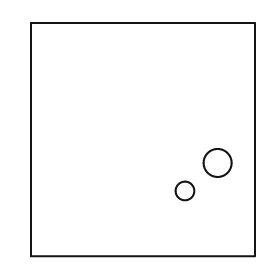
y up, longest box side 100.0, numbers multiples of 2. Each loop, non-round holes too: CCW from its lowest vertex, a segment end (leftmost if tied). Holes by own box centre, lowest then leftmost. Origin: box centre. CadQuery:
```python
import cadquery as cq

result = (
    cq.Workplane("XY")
    .moveTo(-48.0, -50.0)
    .lineTo(48.0, -50.0)
    .lineTo(48.0, 50.0)
    .lineTo(-48.0, 50.0)
    .close()
    .moveTo(18.0, -22.0)
    .circle(4.0)
    .moveTo(32.0, -10.0)
    .circle(6.0)
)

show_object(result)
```